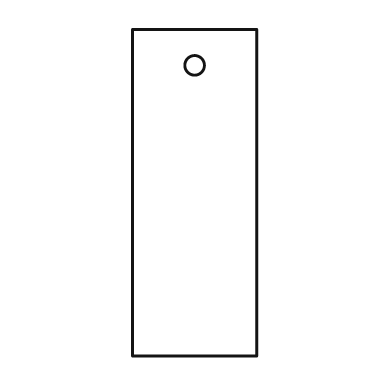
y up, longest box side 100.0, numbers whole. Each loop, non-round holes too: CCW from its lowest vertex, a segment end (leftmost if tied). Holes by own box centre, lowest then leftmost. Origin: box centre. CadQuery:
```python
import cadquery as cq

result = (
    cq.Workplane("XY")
    .moveTo(-19.0, -50.0)
    .lineTo(19.0, -50.0)
    .lineTo(19.0, 50.0)
    .lineTo(-19.0, 50.0)
    .close()
    .moveTo(0.0, 39.0)
    .circle(3.0)
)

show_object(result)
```